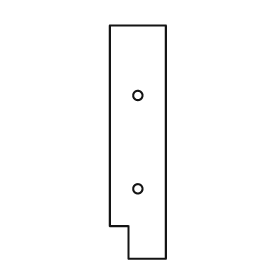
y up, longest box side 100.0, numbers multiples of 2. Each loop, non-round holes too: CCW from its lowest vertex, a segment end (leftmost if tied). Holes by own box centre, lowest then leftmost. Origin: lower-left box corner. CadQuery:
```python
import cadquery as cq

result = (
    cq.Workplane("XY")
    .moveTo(8.0, 0.0)
    .lineTo(24.0, 0.0)
    .lineTo(24.0, 100.0)
    .lineTo(0.0, 100.0)
    .lineTo(0.0, 14.0)
    .lineTo(8.0, 14.0)
    .close()
    .moveTo(12.0, 30.0)
    .circle(2.0)
    .moveTo(12.0, 70.0)
    .circle(2.0)
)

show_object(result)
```